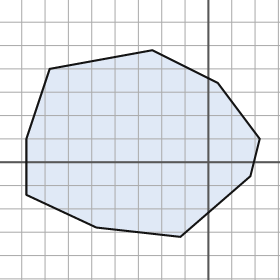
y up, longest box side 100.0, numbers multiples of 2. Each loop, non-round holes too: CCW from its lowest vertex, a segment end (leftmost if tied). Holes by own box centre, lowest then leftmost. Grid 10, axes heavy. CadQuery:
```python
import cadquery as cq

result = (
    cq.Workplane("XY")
    .moveTo(-12.0, -32.0)
    .lineTo(18.0, -6.0)
    .lineTo(22.0, 10.0)
    .lineTo(4.0, 34.0)
    .lineTo(-24.0, 48.0)
    .lineTo(-68.0, 40.0)
    .lineTo(-78.0, 10.0)
    .lineTo(-78.0, -14.0)
    .lineTo(-48.0, -28.0)
    .close()
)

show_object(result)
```